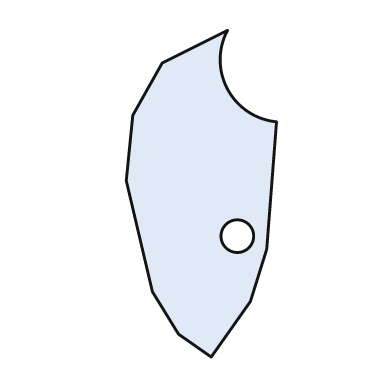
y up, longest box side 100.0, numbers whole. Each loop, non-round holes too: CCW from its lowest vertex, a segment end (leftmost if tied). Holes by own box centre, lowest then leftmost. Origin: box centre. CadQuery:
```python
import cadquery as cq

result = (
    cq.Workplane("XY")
    .moveTo(3.0, -50.0)
    .lineTo(15.0, -33.0)
    .lineTo(20.0, -17.0)
    .lineTo(23.0, 22.0)
    .threePointArc((8.0, 32.0), (8.0, 50.0))
    .lineTo(-12.0, 40.0)
    .lineTo(-21.0, 24.0)
    .lineTo(-23.0, 4.0)
    .lineTo(-15.0, -30.0)
    .lineTo(-7.0, -43.0)
    .close()
    .moveTo(11.0, -13.0)
    .circle(5.0)
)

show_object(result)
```